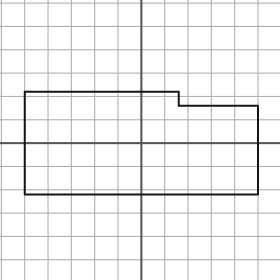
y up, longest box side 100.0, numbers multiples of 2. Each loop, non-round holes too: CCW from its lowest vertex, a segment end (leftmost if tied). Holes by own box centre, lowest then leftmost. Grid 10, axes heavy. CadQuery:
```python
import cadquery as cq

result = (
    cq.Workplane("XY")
    .moveTo(-50.0, -22.0)
    .lineTo(50.0, -22.0)
    .lineTo(50.0, 16.0)
    .lineTo(16.0, 16.0)
    .lineTo(16.0, 22.0)
    .lineTo(-50.0, 22.0)
    .close()
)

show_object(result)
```